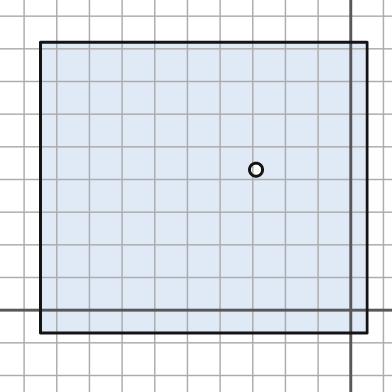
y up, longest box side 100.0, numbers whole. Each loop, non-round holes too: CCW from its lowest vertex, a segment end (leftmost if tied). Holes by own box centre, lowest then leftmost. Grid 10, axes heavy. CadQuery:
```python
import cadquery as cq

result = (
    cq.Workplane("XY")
    .moveTo(-95.0, -7.0)
    .lineTo(5.0, -7.0)
    .lineTo(5.0, 82.0)
    .lineTo(-95.0, 82.0)
    .close()
    .moveTo(-29.0, 43.0)
    .circle(2.0)
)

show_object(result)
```